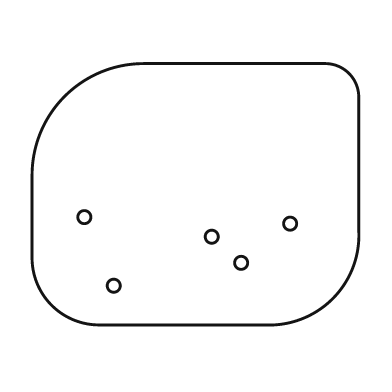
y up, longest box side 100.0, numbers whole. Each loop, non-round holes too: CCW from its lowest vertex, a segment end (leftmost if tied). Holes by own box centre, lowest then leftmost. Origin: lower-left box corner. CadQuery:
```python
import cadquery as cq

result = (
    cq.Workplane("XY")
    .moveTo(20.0, 0.0)
    .lineTo(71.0, 0.0)
    .threePointArc((92.0, 8.0), (100.0, 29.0))
    .lineTo(100.0, 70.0)
    .threePointArc((97.0, 77.0), (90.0, 80.0))
    .lineTo(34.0, 80.0)
    .threePointArc((10.0, 70.0), (0.0, 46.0))
    .lineTo(0.0, 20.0)
    .threePointArc((6.0, 6.0), (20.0, 0.0))
    .close()
    .moveTo(25.0, 12.0)
    .circle(2.0)
    .moveTo(64.0, 19.0)
    .circle(2.0)
    .moveTo(55.0, 27.0)
    .circle(2.0)
    .moveTo(79.0, 31.0)
    .circle(2.0)
    .moveTo(16.0, 33.0)
    .circle(2.0)
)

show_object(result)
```